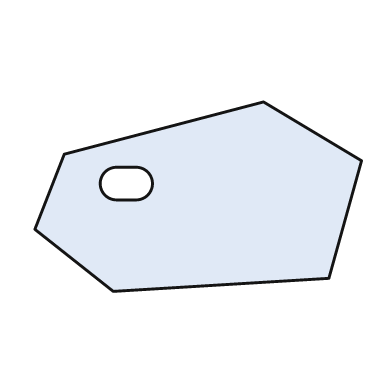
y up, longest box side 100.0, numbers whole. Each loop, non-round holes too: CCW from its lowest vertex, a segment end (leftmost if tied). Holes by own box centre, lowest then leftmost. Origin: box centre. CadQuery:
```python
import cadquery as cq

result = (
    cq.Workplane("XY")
    .moveTo(-26.0, -29.0)
    .lineTo(40.0, -25.0)
    .lineTo(50.0, 11.0)
    .lineTo(20.0, 29.0)
    .lineTo(-41.0, 13.0)
    .lineTo(-50.0, -10.0)
    .close()
    .moveTo(-25.0, -1.0)
    .lineTo(-19.0, -1.0)
    .threePointArc((-14.0, 4.0), (-19.0, 9.0))
    .lineTo(-25.0, 9.0)
    .threePointArc((-30.0, 4.0), (-25.0, -1.0))
    .close()
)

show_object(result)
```